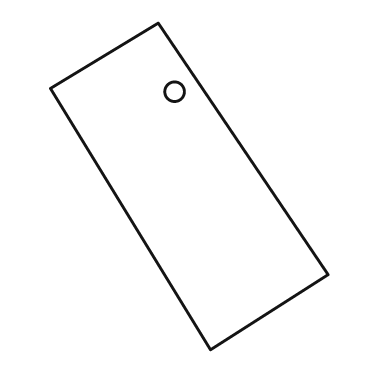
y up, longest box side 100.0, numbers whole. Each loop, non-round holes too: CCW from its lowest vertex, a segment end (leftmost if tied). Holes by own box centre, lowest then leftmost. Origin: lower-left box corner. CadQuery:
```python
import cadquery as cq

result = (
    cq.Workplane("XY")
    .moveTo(49.0, 0.0)
    .lineTo(85.0, 23.0)
    .lineTo(33.0, 100.0)
    .lineTo(0.0, 80.0)
    .close()
    .moveTo(38.0, 79.0)
    .circle(3.0)
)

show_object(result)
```